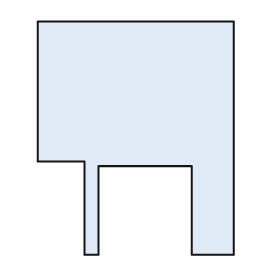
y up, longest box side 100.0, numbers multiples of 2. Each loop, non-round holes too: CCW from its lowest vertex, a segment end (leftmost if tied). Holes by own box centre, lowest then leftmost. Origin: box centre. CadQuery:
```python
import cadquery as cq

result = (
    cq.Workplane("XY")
    .moveTo(-22.0, -50.0)
    .lineTo(-16.0, -50.0)
    .lineTo(-16.0, -12.0)
    .lineTo(24.0, -12.0)
    .lineTo(24.0, -50.0)
    .lineTo(42.0, -50.0)
    .lineTo(42.0, 50.0)
    .lineTo(-42.0, 50.0)
    .lineTo(-42.0, -10.0)
    .lineTo(-22.0, -10.0)
    .close()
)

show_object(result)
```